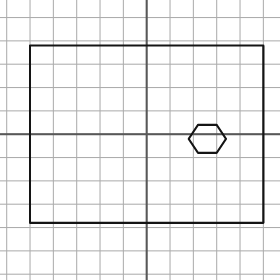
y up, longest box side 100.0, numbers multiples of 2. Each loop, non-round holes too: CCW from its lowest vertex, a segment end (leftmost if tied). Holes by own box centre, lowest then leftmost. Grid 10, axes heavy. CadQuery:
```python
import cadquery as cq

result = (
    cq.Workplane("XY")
    .moveTo(-50.0, -38.0)
    .lineTo(50.0, -38.0)
    .lineTo(50.0, 38.0)
    .lineTo(-50.0, 38.0)
    .close()
    .moveTo(22.0, -8.0)
    .lineTo(30.0, -8.0)
    .lineTo(34.0, -2.0)
    .lineTo(30.0, 4.0)
    .lineTo(22.0, 4.0)
    .lineTo(18.0, -2.0)
    .close()
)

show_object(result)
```